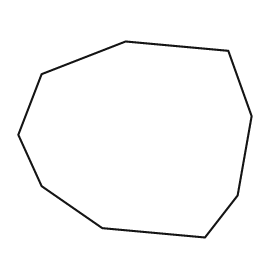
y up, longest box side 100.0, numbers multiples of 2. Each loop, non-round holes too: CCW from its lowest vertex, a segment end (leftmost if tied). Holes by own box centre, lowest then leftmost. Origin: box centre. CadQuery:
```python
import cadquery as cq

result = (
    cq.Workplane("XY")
    .moveTo(30.0, -42.0)
    .lineTo(44.0, -24.0)
    .lineTo(50.0, 10.0)
    .lineTo(40.0, 38.0)
    .lineTo(-4.0, 42.0)
    .lineTo(-40.0, 28.0)
    .lineTo(-50.0, 2.0)
    .lineTo(-40.0, -20.0)
    .lineTo(-14.0, -38.0)
    .close()
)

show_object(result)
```